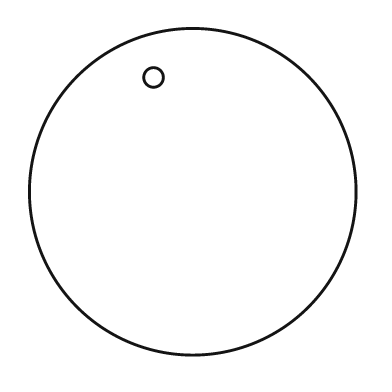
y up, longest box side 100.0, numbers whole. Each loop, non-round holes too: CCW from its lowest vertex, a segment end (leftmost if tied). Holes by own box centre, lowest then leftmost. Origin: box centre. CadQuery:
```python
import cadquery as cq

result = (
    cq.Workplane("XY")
    .moveTo(0.0, 0.0)
    .circle(50.0)
    .moveTo(-12.0, 35.0)
    .circle(3.0)
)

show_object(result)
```